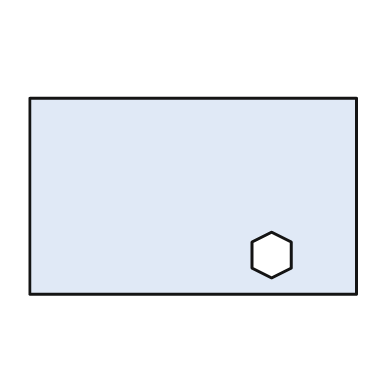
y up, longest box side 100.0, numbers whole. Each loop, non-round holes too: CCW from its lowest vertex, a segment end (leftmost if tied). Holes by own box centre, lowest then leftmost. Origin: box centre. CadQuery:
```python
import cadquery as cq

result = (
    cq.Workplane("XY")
    .moveTo(-50.0, -30.0)
    .lineTo(50.0, -30.0)
    .lineTo(50.0, 30.0)
    .lineTo(-50.0, 30.0)
    .close()
    .moveTo(24.0, -25.0)
    .lineTo(30.0, -22.0)
    .lineTo(30.0, -14.0)
    .lineTo(24.0, -11.0)
    .lineTo(18.0, -14.0)
    .lineTo(18.0, -22.0)
    .close()
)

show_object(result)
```